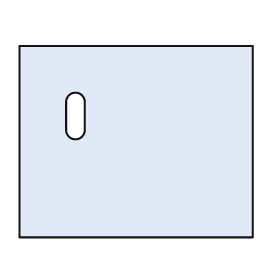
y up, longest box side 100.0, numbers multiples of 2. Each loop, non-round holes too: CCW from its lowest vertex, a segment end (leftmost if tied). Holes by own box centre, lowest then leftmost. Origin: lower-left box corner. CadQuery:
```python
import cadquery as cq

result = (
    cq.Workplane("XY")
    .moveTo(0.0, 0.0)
    .lineTo(100.0, 0.0)
    .lineTo(100.0, 82.0)
    .lineTo(0.0, 82.0)
    .close()
    .moveTo(20.0, 46.0)
    .threePointArc((24.0, 42.0), (28.0, 46.0))
    .lineTo(28.0, 58.0)
    .threePointArc((24.0, 62.0), (20.0, 58.0))
    .close()
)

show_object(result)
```